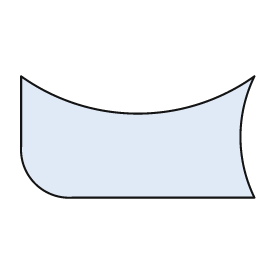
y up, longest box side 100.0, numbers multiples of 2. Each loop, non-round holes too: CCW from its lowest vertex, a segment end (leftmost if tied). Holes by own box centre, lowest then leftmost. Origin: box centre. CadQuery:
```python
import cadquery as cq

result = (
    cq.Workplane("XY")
    .moveTo(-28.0, -26.0)
    .lineTo(50.0, -26.0)
    .threePointArc((44.0, 0.0), (50.0, 26.0))
    .threePointArc((0.0, 10.0), (-50.0, 26.0))
    .lineTo(-50.0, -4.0)
    .threePointArc((-44.0, -20.0), (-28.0, -26.0))
    .close()
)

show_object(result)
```